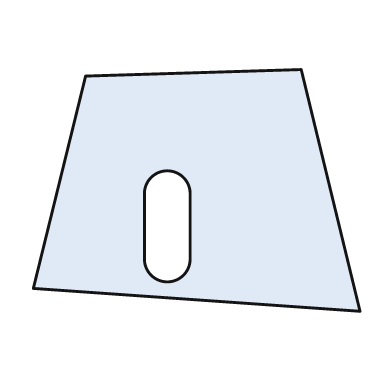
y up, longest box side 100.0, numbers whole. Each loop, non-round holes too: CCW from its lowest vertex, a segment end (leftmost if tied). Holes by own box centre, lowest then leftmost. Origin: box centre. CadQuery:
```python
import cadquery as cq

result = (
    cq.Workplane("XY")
    .moveTo(50.0, -37.0)
    .lineTo(32.0, 37.0)
    .lineTo(-34.0, 35.0)
    .lineTo(-50.0, -30.0)
    .close()
    .moveTo(-16.0, -21.0)
    .threePointArc((-9.0, -28.0), (-2.0, -21.0))
    .lineTo(-2.0, -1.0)
    .threePointArc((-9.0, 6.0), (-16.0, -1.0))
    .close()
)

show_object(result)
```